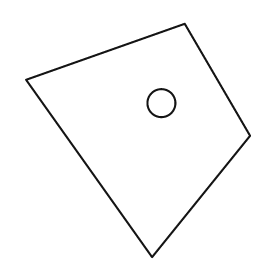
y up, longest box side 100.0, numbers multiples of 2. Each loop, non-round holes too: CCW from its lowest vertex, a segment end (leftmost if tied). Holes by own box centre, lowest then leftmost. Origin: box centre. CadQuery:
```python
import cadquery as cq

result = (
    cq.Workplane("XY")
    .moveTo(6.0, -50.0)
    .lineTo(48.0, 2.0)
    .lineTo(20.0, 50.0)
    .lineTo(-48.0, 26.0)
    .close()
    .moveTo(10.0, 16.0)
    .circle(6.0)
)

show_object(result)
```